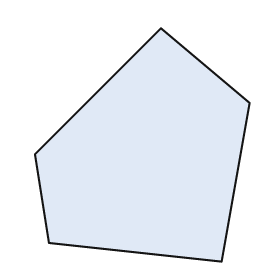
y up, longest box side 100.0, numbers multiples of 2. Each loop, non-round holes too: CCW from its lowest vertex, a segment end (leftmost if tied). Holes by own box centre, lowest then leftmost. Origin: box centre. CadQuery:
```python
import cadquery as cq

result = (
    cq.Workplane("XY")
    .moveTo(34.0, -50.0)
    .lineTo(46.0, 18.0)
    .lineTo(8.0, 50.0)
    .lineTo(-46.0, -4.0)
    .lineTo(-40.0, -42.0)
    .close()
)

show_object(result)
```